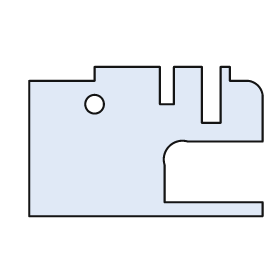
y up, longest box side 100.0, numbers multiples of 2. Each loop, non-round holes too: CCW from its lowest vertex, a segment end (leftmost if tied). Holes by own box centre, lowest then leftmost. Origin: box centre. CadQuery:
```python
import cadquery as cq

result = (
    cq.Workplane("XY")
    .moveTo(-50.0, -32.0)
    .lineTo(50.0, -32.0)
    .lineTo(50.0, -26.0)
    .lineTo(8.0, -26.0)
    .lineTo(8.0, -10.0)
    .threePointArc((10.0, -2.0), (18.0, 0.0))
    .lineTo(50.0, 0.0)
    .lineTo(50.0, 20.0)
    .threePointArc((48.0, 24.0), (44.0, 26.0))
    .lineTo(36.0, 26.0)
    .lineTo(36.0, 32.0)
    .lineTo(32.0, 32.0)
    .lineTo(32.0, 8.0)
    .lineTo(24.0, 8.0)
    .lineTo(24.0, 32.0)
    .lineTo(12.0, 32.0)
    .lineTo(12.0, 16.0)
    .lineTo(6.0, 16.0)
    .lineTo(6.0, 32.0)
    .lineTo(-22.0, 32.0)
    .lineTo(-22.0, 26.0)
    .lineTo(-50.0, 26.0)
    .close()
    .moveTo(-22.0, 16.0)
    .circle(4.0)
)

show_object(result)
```